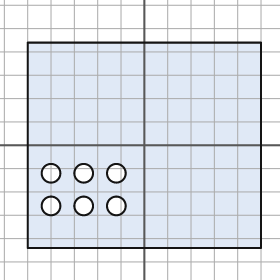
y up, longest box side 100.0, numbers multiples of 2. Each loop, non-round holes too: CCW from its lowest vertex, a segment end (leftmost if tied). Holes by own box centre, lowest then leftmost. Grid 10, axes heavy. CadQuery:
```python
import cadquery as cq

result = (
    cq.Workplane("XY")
    .moveTo(-50.0, -44.0)
    .lineTo(50.0, -44.0)
    .lineTo(50.0, 44.0)
    .lineTo(-50.0, 44.0)
    .close()
    .moveTo(-40.0, -26.0)
    .circle(4.0)
    .moveTo(-26.0, -26.0)
    .circle(4.0)
    .moveTo(-12.0, -26.0)
    .circle(4.0)
    .moveTo(-40.0, -12.0)
    .circle(4.0)
    .moveTo(-26.0, -12.0)
    .circle(4.0)
    .moveTo(-12.0, -12.0)
    .circle(4.0)
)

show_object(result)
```